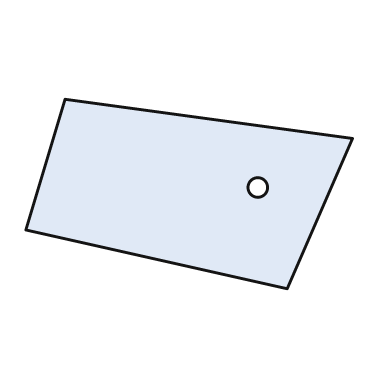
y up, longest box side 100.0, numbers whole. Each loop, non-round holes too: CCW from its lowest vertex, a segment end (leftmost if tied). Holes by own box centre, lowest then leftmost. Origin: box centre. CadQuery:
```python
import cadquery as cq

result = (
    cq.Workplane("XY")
    .moveTo(30.0, -29.0)
    .lineTo(50.0, 17.0)
    .lineTo(-38.0, 29.0)
    .lineTo(-50.0, -11.0)
    .close()
    .moveTo(21.0, 2.0)
    .circle(3.0)
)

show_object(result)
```